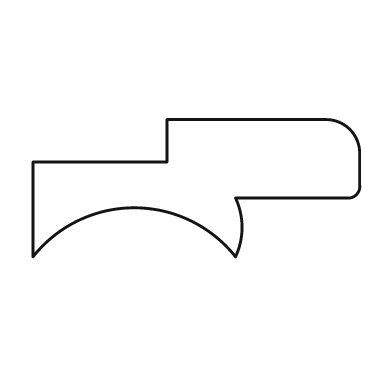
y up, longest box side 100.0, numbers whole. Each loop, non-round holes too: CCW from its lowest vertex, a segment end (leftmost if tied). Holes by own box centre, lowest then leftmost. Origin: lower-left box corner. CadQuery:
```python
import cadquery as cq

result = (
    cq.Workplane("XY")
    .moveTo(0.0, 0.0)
    .threePointArc((31.0, 15.0), (62.0, 0.0))
    .threePointArc((64.0, 9.0), (62.0, 18.0))
    .lineTo(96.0, 18.0)
    .threePointArc((99.0, 19.0), (100.0, 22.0))
    .lineTo(100.0, 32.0)
    .threePointArc((97.0, 39.0), (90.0, 42.0))
    .lineTo(41.0, 42.0)
    .lineTo(41.0, 29.0)
    .lineTo(0.0, 29.0)
    .close()
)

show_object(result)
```